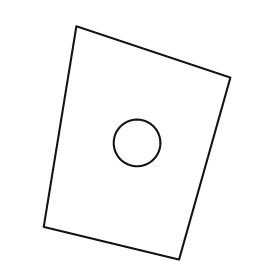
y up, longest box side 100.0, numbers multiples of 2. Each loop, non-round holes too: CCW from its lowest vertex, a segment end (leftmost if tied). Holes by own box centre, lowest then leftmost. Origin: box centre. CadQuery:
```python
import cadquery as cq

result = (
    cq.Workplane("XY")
    .moveTo(18.0, -50.0)
    .lineTo(40.0, 28.0)
    .lineTo(-26.0, 50.0)
    .lineTo(-40.0, -36.0)
    .close()
    .moveTo(0.0, 0.0)
    .circle(10.0)
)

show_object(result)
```